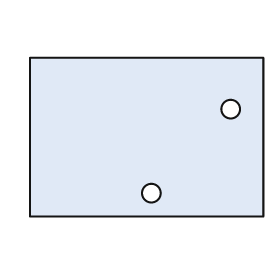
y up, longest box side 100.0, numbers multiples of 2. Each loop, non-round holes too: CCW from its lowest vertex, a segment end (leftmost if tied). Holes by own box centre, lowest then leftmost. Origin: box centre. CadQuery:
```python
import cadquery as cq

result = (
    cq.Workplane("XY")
    .moveTo(-50.0, -34.0)
    .lineTo(50.0, -34.0)
    .lineTo(50.0, 34.0)
    .lineTo(-50.0, 34.0)
    .close()
    .moveTo(2.0, -24.0)
    .circle(4.0)
    .moveTo(36.0, 12.0)
    .circle(4.0)
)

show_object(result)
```